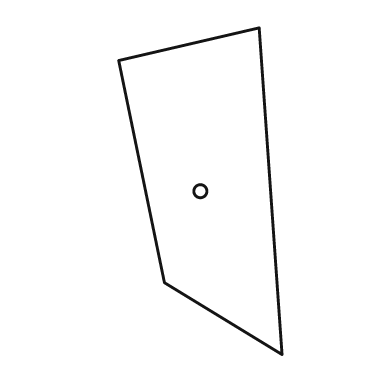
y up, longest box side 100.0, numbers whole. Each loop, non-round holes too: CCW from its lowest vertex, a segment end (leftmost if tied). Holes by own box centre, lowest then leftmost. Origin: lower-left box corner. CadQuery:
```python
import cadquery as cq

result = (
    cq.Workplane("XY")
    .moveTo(50.0, 0.0)
    .lineTo(43.0, 100.0)
    .lineTo(0.0, 90.0)
    .lineTo(14.0, 22.0)
    .close()
    .moveTo(25.0, 50.0)
    .circle(2.0)
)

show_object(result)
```